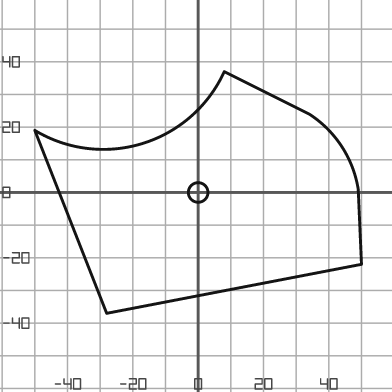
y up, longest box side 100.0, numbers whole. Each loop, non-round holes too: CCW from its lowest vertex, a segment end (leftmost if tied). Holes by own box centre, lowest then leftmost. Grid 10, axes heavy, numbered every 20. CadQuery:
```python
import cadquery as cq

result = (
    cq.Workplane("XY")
    .moveTo(-28.0, -37.0)
    .lineTo(50.0, -22.0)
    .lineTo(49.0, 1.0)
    .threePointArc((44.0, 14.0), (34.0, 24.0))
    .lineTo(8.0, 37.0)
    .threePointArc((-17.0, 15.0), (-50.0, 19.0))
    .close()
    .moveTo(0.0, 0.0)
    .circle(3.0)
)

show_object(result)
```